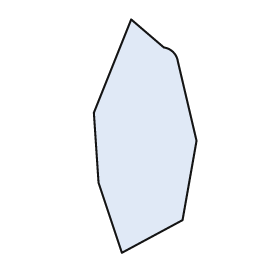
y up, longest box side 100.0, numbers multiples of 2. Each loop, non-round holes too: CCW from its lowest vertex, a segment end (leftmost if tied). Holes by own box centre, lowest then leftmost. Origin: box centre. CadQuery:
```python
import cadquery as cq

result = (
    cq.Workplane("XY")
    .moveTo(-10.0, -50.0)
    .lineTo(16.0, -36.0)
    .lineTo(22.0, -2.0)
    .lineTo(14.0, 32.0)
    .threePointArc((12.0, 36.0), (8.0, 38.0))
    .lineTo(-6.0, 50.0)
    .lineTo(-22.0, 10.0)
    .lineTo(-20.0, -20.0)
    .close()
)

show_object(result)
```